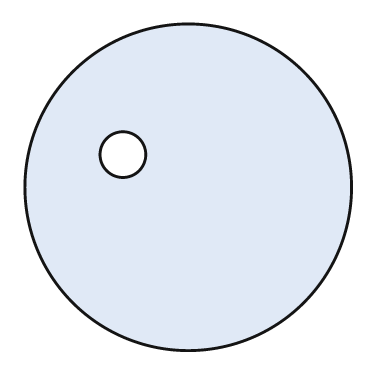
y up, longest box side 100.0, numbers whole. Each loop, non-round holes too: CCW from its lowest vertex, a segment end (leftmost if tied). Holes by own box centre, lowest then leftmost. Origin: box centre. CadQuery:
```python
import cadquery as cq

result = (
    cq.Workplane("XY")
    .moveTo(0.0, 0.0)
    .circle(50.0)
    .moveTo(-20.0, 10.0)
    .circle(7.0)
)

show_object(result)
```